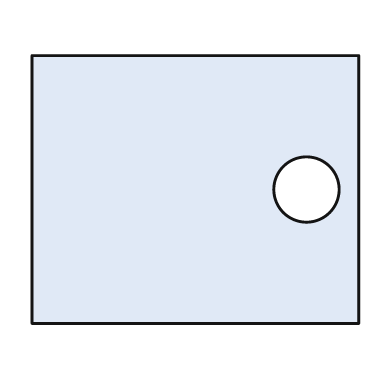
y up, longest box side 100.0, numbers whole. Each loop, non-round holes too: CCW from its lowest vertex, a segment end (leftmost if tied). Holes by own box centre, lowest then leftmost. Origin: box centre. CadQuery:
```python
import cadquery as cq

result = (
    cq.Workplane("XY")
    .moveTo(-50.0, -41.0)
    .lineTo(50.0, -41.0)
    .lineTo(50.0, 41.0)
    .lineTo(-50.0, 41.0)
    .close()
    .moveTo(34.0, 0.0)
    .circle(10.0)
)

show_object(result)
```